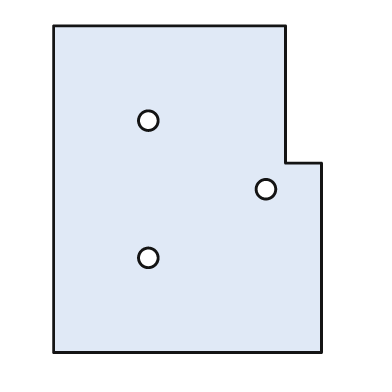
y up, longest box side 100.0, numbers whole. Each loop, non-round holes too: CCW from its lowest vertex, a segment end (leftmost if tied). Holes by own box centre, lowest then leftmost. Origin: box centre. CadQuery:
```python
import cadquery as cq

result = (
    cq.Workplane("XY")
    .moveTo(-41.0, -50.0)
    .lineTo(41.0, -50.0)
    .lineTo(41.0, 8.0)
    .lineTo(30.0, 8.0)
    .lineTo(30.0, 50.0)
    .lineTo(-41.0, 50.0)
    .close()
    .moveTo(-12.0, -21.0)
    .circle(3.0)
    .moveTo(24.0, 0.0)
    .circle(3.0)
    .moveTo(-12.0, 21.0)
    .circle(3.0)
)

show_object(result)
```